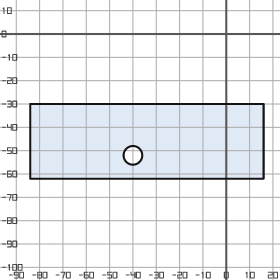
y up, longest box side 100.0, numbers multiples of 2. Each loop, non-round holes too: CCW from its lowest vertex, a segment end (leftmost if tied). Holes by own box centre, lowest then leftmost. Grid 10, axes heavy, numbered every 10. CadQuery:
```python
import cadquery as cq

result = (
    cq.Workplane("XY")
    .moveTo(-84.0, -62.0)
    .lineTo(16.0, -62.0)
    .lineTo(16.0, -30.0)
    .lineTo(-84.0, -30.0)
    .close()
    .moveTo(-40.0, -52.0)
    .circle(4.0)
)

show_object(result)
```